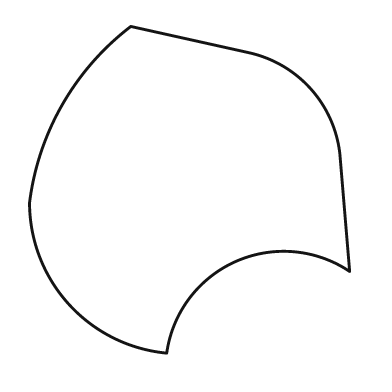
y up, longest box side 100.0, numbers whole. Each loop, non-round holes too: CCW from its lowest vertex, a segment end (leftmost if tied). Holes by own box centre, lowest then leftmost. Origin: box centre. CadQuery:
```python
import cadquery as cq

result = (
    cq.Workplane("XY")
    .moveTo(-7.0, -50.0)
    .threePointArc((14.0, -22.0), (49.0, -25.0))
    .lineTo(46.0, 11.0)
    .threePointArc((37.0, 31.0), (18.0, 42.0))
    .lineTo(-18.0, 50.0)
    .threePointArc((-39.0, 26.0), (-49.0, -4.0))
    .threePointArc((-37.0, -35.0), (-7.0, -50.0))
    .close()
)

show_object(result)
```